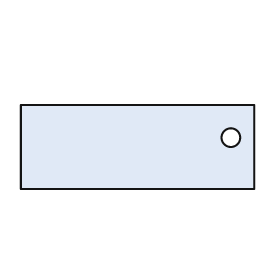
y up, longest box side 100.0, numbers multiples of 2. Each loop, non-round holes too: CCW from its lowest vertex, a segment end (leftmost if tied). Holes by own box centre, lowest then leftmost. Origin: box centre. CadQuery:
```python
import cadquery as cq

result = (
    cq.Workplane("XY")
    .moveTo(-50.0, -18.0)
    .lineTo(50.0, -18.0)
    .lineTo(50.0, 18.0)
    .lineTo(-50.0, 18.0)
    .close()
    .moveTo(40.0, 4.0)
    .circle(4.0)
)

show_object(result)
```